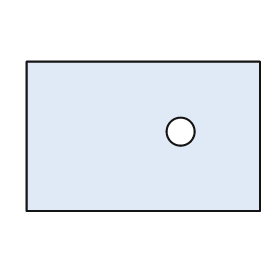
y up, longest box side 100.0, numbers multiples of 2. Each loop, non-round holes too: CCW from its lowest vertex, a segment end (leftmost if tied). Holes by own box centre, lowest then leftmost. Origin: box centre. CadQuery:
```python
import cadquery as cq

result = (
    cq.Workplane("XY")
    .moveTo(-50.0, -32.0)
    .lineTo(50.0, -32.0)
    .lineTo(50.0, 32.0)
    .lineTo(-50.0, 32.0)
    .close()
    .moveTo(16.0, 2.0)
    .circle(6.0)
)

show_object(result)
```